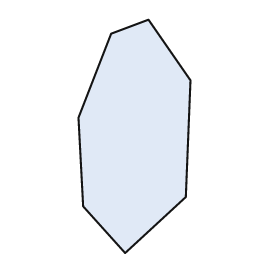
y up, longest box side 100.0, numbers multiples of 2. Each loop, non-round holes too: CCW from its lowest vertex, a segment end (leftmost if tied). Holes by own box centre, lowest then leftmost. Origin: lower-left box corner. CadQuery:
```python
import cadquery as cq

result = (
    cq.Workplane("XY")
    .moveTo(20.0, 0.0)
    .lineTo(46.0, 24.0)
    .lineTo(48.0, 74.0)
    .lineTo(30.0, 100.0)
    .lineTo(14.0, 94.0)
    .lineTo(0.0, 58.0)
    .lineTo(2.0, 20.0)
    .close()
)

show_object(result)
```